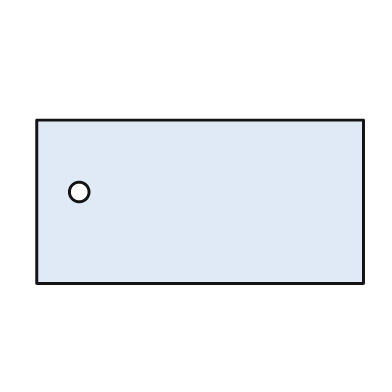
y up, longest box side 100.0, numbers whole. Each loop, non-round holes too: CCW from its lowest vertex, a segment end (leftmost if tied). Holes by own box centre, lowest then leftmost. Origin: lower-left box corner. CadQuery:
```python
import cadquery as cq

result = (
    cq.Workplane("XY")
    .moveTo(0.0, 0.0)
    .lineTo(100.0, 0.0)
    .lineTo(100.0, 50.0)
    .lineTo(0.0, 50.0)
    .close()
    .moveTo(13.0, 28.0)
    .circle(3.0)
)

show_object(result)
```